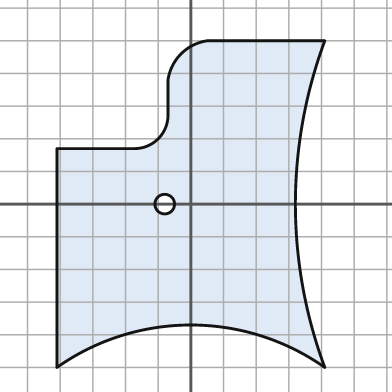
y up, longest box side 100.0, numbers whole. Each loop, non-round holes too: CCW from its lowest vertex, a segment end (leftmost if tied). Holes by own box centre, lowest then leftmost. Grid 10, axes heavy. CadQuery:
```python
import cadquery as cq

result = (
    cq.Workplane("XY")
    .moveTo(-41.0, -50.0)
    .threePointArc((0.0, -37.0), (41.0, -50.0))
    .threePointArc((32.0, 0.0), (41.0, 50.0))
    .lineTo(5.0, 50.0)
    .threePointArc((-3.0, 46.0), (-7.0, 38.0))
    .lineTo(-7.0, 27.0)
    .threePointArc((-10.0, 20.0), (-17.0, 17.0))
    .lineTo(-41.0, 17.0)
    .close()
    .moveTo(-8.0, 0.0)
    .circle(3.0)
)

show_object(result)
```